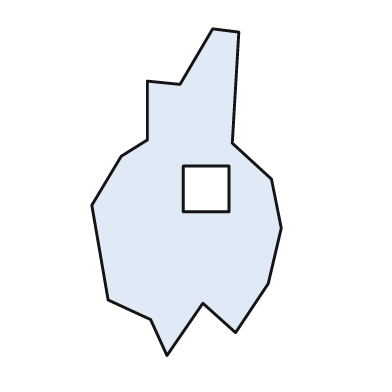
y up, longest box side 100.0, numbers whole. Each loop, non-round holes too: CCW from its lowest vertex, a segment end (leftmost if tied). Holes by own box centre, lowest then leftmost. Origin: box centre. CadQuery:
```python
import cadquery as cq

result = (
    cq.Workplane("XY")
    .moveTo(-6.0, -50.0)
    .lineTo(5.0, -34.0)
    .lineTo(15.0, -43.0)
    .lineTo(25.0, -28.0)
    .lineTo(29.0, -11.0)
    .lineTo(26.0, 4.0)
    .lineTo(14.0, 15.0)
    .lineTo(16.0, 49.0)
    .lineTo(8.0, 50.0)
    .lineTo(-2.0, 33.0)
    .lineTo(-12.0, 34.0)
    .lineTo(-12.0, 16.0)
    .lineTo(-20.0, 11.0)
    .lineTo(-29.0, -4.0)
    .lineTo(-24.0, -33.0)
    .lineTo(-11.0, -39.0)
    .close()
    .moveTo(-1.0, -6.0)
    .lineTo(13.0, -6.0)
    .lineTo(13.0, 8.0)
    .lineTo(-1.0, 8.0)
    .close()
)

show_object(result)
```